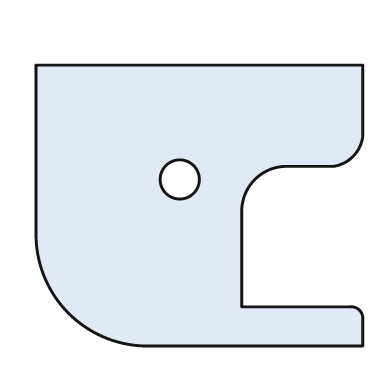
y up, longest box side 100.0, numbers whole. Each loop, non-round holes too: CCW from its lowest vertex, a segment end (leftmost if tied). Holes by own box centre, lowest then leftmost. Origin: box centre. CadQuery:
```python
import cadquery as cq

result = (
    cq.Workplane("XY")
    .moveTo(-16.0, -43.0)
    .lineTo(50.0, -43.0)
    .lineTo(50.0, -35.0)
    .threePointArc((49.0, -32.0), (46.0, -31.0))
    .lineTo(13.0, -31.0)
    .lineTo(13.0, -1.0)
    .threePointArc((17.0, 8.0), (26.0, 12.0))
    .lineTo(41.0, 12.0)
    .threePointArc((47.0, 15.0), (50.0, 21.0))
    .lineTo(50.0, 43.0)
    .lineTo(-50.0, 43.0)
    .lineTo(-50.0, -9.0)
    .threePointArc((-40.0, -33.0), (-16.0, -43.0))
    .close()
    .moveTo(-6.0, 8.0)
    .circle(6.0)
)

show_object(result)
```